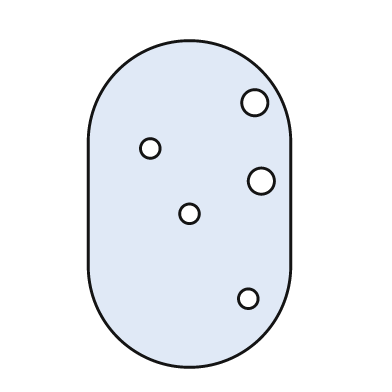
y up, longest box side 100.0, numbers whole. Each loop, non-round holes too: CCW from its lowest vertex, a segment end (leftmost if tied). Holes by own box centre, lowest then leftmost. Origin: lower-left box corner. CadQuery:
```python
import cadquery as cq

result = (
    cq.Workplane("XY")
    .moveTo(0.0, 31.0)
    .threePointArc((31.0, 0.0), (62.0, 31.0))
    .lineTo(62.0, 69.0)
    .threePointArc((31.0, 100.0), (0.0, 69.0))
    .close()
    .moveTo(49.0, 21.0)
    .circle(3.0)
    .moveTo(31.0, 47.0)
    .circle(3.0)
    .moveTo(53.0, 57.0)
    .circle(4.0)
    .moveTo(19.0, 67.0)
    .circle(3.0)
    .moveTo(51.0, 81.0)
    .circle(4.0)
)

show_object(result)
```